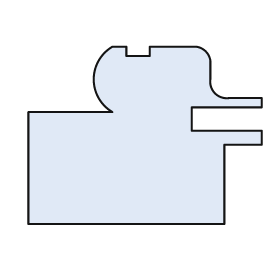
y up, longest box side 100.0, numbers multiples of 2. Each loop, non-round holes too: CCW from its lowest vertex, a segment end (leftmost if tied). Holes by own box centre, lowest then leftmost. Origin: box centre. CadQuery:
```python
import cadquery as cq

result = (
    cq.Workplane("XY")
    .moveTo(-50.0, -38.0)
    .lineTo(34.0, -38.0)
    .lineTo(34.0, -4.0)
    .lineTo(50.0, -4.0)
    .lineTo(50.0, 2.0)
    .lineTo(20.0, 2.0)
    .lineTo(20.0, 12.0)
    .lineTo(50.0, 12.0)
    .lineTo(50.0, 16.0)
    .lineTo(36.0, 16.0)
    .threePointArc((30.0, 18.0), (28.0, 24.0))
    .lineTo(28.0, 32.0)
    .threePointArc((26.0, 36.0), (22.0, 38.0))
    .lineTo(2.0, 38.0)
    .lineTo(2.0, 34.0)
    .lineTo(-8.0, 34.0)
    .lineTo(-8.0, 38.0)
    .lineTo(-14.0, 38.0)
    .threePointArc((-22.0, 24.0), (-14.0, 10.0))
    .lineTo(-50.0, 10.0)
    .close()
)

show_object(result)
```